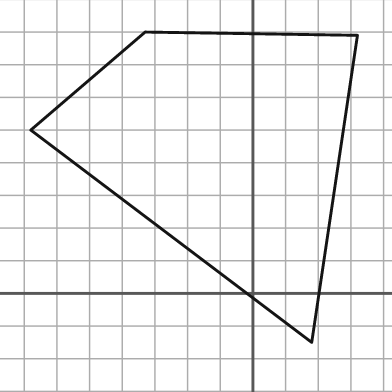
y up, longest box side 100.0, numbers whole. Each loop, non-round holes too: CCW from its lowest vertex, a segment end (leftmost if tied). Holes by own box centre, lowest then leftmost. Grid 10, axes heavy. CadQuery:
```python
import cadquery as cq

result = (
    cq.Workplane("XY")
    .moveTo(18.0, -15.0)
    .lineTo(32.0, 79.0)
    .lineTo(-33.0, 80.0)
    .lineTo(-68.0, 50.0)
    .close()
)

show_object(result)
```